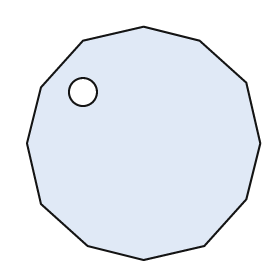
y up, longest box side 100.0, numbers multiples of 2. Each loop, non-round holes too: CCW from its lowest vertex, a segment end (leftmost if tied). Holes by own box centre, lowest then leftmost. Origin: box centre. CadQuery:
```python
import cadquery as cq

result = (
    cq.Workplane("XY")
    .moveTo(0.0, -50.0)
    .lineTo(26.0, -44.0)
    .lineTo(44.0, -24.0)
    .lineTo(50.0, 0.0)
    .lineTo(44.0, 26.0)
    .lineTo(24.0, 44.0)
    .lineTo(0.0, 50.0)
    .lineTo(-26.0, 44.0)
    .lineTo(-44.0, 24.0)
    .lineTo(-50.0, 0.0)
    .lineTo(-44.0, -26.0)
    .lineTo(-24.0, -44.0)
    .close()
    .moveTo(-26.0, 22.0)
    .circle(6.0)
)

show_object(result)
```